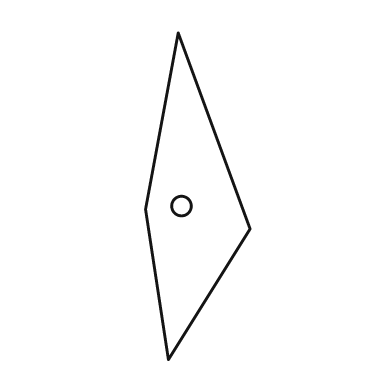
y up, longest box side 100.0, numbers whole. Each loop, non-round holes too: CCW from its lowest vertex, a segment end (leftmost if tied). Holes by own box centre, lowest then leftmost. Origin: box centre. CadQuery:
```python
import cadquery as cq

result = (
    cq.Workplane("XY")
    .moveTo(-9.0, -50.0)
    .lineTo(16.0, -10.0)
    .lineTo(-6.0, 50.0)
    .lineTo(-16.0, -4.0)
    .close()
    .moveTo(-5.0, -3.0)
    .circle(3.0)
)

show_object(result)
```